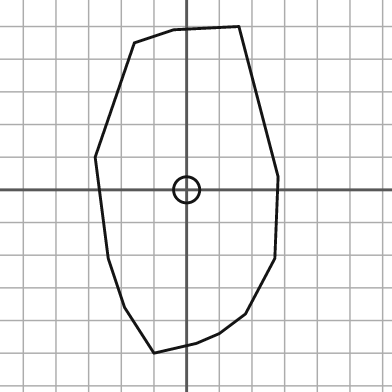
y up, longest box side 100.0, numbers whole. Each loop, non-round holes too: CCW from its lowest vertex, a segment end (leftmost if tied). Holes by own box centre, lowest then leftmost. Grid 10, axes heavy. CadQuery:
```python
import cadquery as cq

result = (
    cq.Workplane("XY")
    .moveTo(-10.0, -50.0)
    .lineTo(3.0, -47.0)
    .lineTo(10.0, -44.0)
    .lineTo(18.0, -38.0)
    .lineTo(27.0, -21.0)
    .lineTo(28.0, 4.0)
    .lineTo(16.0, 50.0)
    .lineTo(-4.0, 49.0)
    .lineTo(-16.0, 45.0)
    .lineTo(-28.0, 10.0)
    .lineTo(-24.0, -21.0)
    .lineTo(-19.0, -36.0)
    .close()
    .moveTo(0.0, 0.0)
    .circle(4.0)
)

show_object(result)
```